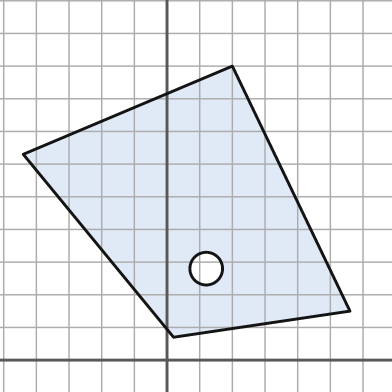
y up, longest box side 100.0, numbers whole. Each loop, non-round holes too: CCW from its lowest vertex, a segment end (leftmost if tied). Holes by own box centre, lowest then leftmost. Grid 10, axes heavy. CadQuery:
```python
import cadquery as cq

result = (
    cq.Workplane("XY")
    .moveTo(2.0, 7.0)
    .lineTo(56.0, 15.0)
    .lineTo(20.0, 90.0)
    .lineTo(-44.0, 63.0)
    .close()
    .moveTo(12.0, 28.0)
    .circle(5.0)
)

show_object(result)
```